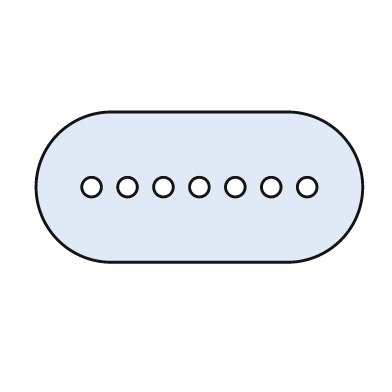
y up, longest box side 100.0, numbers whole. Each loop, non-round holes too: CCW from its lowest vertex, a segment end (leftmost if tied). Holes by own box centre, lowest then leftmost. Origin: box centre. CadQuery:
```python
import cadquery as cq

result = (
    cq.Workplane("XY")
    .moveTo(-27.0, -23.0)
    .lineTo(27.0, -23.0)
    .threePointArc((50.0, 0.0), (27.0, 23.0))
    .lineTo(-27.0, 23.0)
    .threePointArc((-50.0, 0.0), (-27.0, -23.0))
    .close()
    .moveTo(-33.0, 0.0)
    .circle(3.0)
    .moveTo(-22.0, 0.0)
    .circle(3.0)
    .moveTo(-11.0, 0.0)
    .circle(3.0)
    .moveTo(0.0, 0.0)
    .circle(3.0)
    .moveTo(11.0, 0.0)
    .circle(3.0)
    .moveTo(22.0, 0.0)
    .circle(3.0)
    .moveTo(33.0, 0.0)
    .circle(3.0)
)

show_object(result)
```